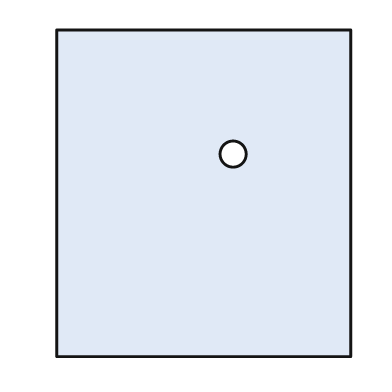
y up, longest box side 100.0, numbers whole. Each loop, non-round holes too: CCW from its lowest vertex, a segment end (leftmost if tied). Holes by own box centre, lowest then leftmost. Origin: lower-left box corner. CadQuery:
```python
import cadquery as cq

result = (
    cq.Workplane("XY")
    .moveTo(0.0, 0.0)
    .lineTo(90.0, 0.0)
    .lineTo(90.0, 100.0)
    .lineTo(0.0, 100.0)
    .close()
    .moveTo(54.0, 62.0)
    .circle(4.0)
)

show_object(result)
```